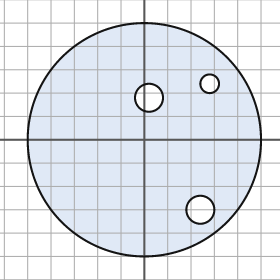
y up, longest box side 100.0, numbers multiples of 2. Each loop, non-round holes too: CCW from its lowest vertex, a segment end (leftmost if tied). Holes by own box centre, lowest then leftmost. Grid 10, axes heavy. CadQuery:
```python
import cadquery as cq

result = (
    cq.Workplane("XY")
    .moveTo(0.0, 0.0)
    .circle(50.0)
    .moveTo(24.0, -30.0)
    .circle(6.0)
    .moveTo(2.0, 18.0)
    .circle(6.0)
    .moveTo(28.0, 24.0)
    .circle(4.0)
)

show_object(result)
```